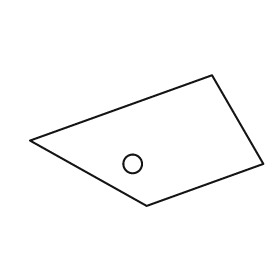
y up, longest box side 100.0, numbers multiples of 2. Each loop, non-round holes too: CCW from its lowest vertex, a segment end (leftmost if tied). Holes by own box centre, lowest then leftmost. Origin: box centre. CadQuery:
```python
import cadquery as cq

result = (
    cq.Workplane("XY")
    .moveTo(0.0, -28.0)
    .lineTo(50.0, -10.0)
    .lineTo(28.0, 28.0)
    .lineTo(-50.0, 0.0)
    .close()
    .moveTo(-6.0, -10.0)
    .circle(4.0)
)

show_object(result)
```